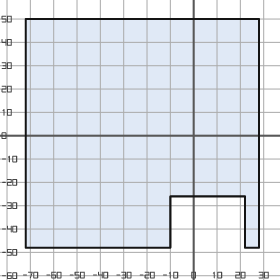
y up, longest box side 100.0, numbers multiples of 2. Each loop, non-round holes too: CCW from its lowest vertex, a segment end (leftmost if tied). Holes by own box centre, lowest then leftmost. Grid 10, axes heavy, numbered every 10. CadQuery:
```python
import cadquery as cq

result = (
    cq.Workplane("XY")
    .moveTo(-72.0, -48.0)
    .lineTo(-10.0, -48.0)
    .lineTo(-10.0, -26.0)
    .lineTo(22.0, -26.0)
    .lineTo(22.0, -48.0)
    .lineTo(28.0, -48.0)
    .lineTo(28.0, 50.0)
    .lineTo(-72.0, 50.0)
    .close()
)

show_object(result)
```